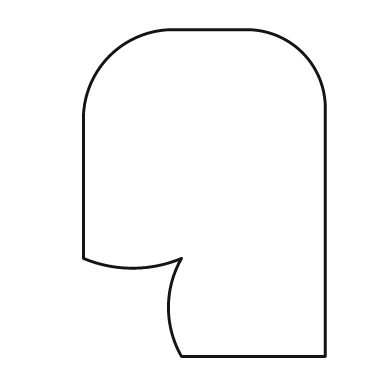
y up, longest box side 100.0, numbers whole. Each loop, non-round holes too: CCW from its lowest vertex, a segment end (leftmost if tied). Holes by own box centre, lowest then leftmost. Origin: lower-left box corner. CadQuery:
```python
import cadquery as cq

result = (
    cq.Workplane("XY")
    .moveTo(30.0, 0.0)
    .lineTo(74.0, 0.0)
    .lineTo(74.0, 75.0)
    .threePointArc((67.0, 93.0), (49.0, 100.0))
    .lineTo(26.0, 100.0)
    .threePointArc((8.0, 92.0), (0.0, 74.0))
    .lineTo(0.0, 30.0)
    .threePointArc((15.0, 27.0), (30.0, 30.0))
    .threePointArc((26.0, 15.0), (30.0, 0.0))
    .close()
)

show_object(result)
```